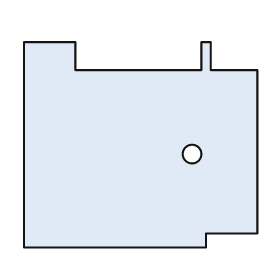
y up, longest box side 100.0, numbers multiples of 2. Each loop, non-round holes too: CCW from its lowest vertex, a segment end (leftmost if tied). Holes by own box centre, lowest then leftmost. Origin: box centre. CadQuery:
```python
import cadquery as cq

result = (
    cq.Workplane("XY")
    .moveTo(-50.0, -44.0)
    .lineTo(28.0, -44.0)
    .lineTo(28.0, -38.0)
    .lineTo(50.0, -38.0)
    .lineTo(50.0, 32.0)
    .lineTo(30.0, 32.0)
    .lineTo(30.0, 44.0)
    .lineTo(26.0, 44.0)
    .lineTo(26.0, 32.0)
    .lineTo(-28.0, 32.0)
    .lineTo(-28.0, 44.0)
    .lineTo(-50.0, 44.0)
    .close()
    .moveTo(22.0, -4.0)
    .circle(4.0)
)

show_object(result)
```